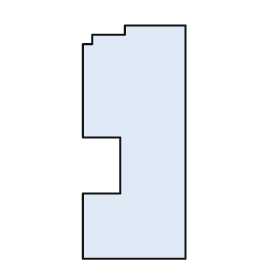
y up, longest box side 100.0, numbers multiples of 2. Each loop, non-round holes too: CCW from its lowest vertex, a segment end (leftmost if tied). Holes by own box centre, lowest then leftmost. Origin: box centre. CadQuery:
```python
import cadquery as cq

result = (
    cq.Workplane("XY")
    .moveTo(-22.0, -50.0)
    .lineTo(22.0, -50.0)
    .lineTo(22.0, 50.0)
    .lineTo(-4.0, 50.0)
    .lineTo(-4.0, 46.0)
    .lineTo(-18.0, 46.0)
    .lineTo(-18.0, 42.0)
    .lineTo(-22.0, 42.0)
    .lineTo(-22.0, 2.0)
    .lineTo(-6.0, 2.0)
    .lineTo(-6.0, -22.0)
    .lineTo(-22.0, -22.0)
    .close()
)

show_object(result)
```